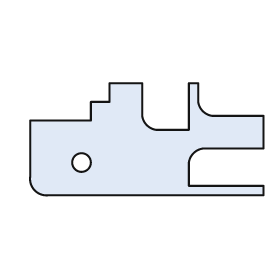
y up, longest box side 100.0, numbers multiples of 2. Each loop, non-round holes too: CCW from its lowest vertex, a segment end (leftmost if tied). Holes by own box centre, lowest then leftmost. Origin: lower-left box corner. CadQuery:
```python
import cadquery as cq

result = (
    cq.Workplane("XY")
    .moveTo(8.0, 0.0)
    .lineTo(100.0, 0.0)
    .lineTo(100.0, 4.0)
    .lineTo(68.0, 4.0)
    .lineTo(68.0, 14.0)
    .threePointArc((70.0, 18.0), (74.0, 20.0))
    .lineTo(100.0, 20.0)
    .lineTo(100.0, 34.0)
    .lineTo(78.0, 34.0)
    .threePointArc((74.0, 36.0), (72.0, 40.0))
    .lineTo(72.0, 48.0)
    .lineTo(68.0, 48.0)
    .lineTo(68.0, 28.0)
    .lineTo(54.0, 28.0)
    .threePointArc((50.0, 30.0), (48.0, 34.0))
    .lineTo(48.0, 48.0)
    .lineTo(34.0, 48.0)
    .lineTo(34.0, 40.0)
    .lineTo(26.0, 40.0)
    .lineTo(26.0, 32.0)
    .lineTo(0.0, 32.0)
    .lineTo(0.0, 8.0)
    .threePointArc((2.0, 2.0), (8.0, 0.0))
    .close()
    .moveTo(22.0, 14.0)
    .circle(4.0)
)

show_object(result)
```